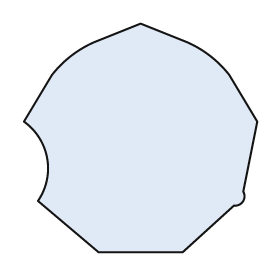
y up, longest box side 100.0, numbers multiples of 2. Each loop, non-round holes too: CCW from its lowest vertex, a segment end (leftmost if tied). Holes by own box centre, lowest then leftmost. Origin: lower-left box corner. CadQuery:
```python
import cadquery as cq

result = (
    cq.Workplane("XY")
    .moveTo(32.0, 0.0)
    .lineTo(68.0, 0.0)
    .lineTo(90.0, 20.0)
    .threePointArc((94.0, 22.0), (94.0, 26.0))
    .lineTo(100.0, 56.0)
    .lineTo(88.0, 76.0)
    .threePointArc((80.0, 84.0), (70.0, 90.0))
    .lineTo(50.0, 98.0)
    .lineTo(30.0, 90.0)
    .threePointArc((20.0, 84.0), (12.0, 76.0))
    .lineTo(0.0, 56.0)
    .threePointArc((10.0, 40.0), (6.0, 22.0))
    .close()
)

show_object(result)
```